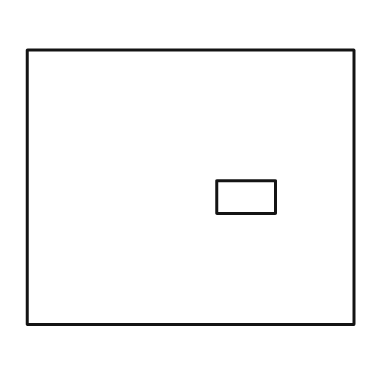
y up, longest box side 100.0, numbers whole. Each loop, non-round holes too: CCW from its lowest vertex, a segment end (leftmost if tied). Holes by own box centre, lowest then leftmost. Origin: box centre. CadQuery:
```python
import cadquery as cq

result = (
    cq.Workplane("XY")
    .moveTo(-50.0, -42.0)
    .lineTo(50.0, -42.0)
    .lineTo(50.0, 42.0)
    .lineTo(-50.0, 42.0)
    .close()
    .moveTo(8.0, -8.0)
    .lineTo(26.0, -8.0)
    .lineTo(26.0, 2.0)
    .lineTo(8.0, 2.0)
    .close()
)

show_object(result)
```